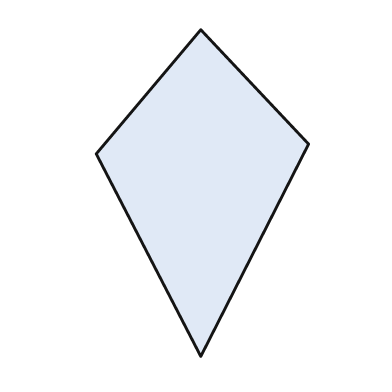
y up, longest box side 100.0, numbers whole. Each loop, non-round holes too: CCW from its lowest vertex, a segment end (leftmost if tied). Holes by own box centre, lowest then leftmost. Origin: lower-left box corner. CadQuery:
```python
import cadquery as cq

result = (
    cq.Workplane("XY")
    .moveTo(32.0, 0.0)
    .lineTo(65.0, 65.0)
    .lineTo(32.0, 100.0)
    .lineTo(0.0, 62.0)
    .close()
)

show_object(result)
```